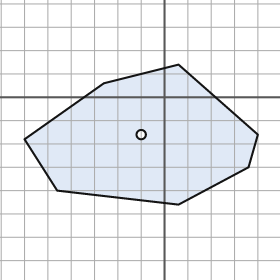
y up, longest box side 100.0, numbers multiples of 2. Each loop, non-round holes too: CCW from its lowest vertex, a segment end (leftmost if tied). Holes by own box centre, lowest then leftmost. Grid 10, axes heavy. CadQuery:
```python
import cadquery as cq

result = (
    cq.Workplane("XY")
    .moveTo(6.0, -46.0)
    .lineTo(36.0, -30.0)
    .lineTo(40.0, -16.0)
    .lineTo(6.0, 14.0)
    .lineTo(-26.0, 6.0)
    .lineTo(-60.0, -18.0)
    .lineTo(-46.0, -40.0)
    .close()
    .moveTo(-10.0, -16.0)
    .circle(2.0)
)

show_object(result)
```